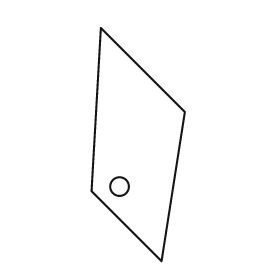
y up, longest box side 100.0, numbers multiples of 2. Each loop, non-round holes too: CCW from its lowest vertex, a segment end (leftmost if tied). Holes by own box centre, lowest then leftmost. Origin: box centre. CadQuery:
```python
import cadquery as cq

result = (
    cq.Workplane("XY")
    .moveTo(10.0, -50.0)
    .lineTo(20.0, 14.0)
    .lineTo(-16.0, 50.0)
    .lineTo(-20.0, -20.0)
    .close()
    .moveTo(-8.0, -18.0)
    .circle(4.0)
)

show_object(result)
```